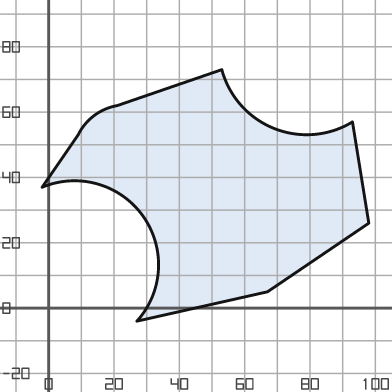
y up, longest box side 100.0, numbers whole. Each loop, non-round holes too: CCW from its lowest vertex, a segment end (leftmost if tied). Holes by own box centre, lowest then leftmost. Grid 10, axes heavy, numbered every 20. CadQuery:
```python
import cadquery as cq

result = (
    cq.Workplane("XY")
    .moveTo(27.0, -4.0)
    .lineTo(67.0, 5.0)
    .lineTo(98.0, 26.0)
    .lineTo(93.0, 57.0)
    .threePointArc((69.0, 55.0), (53.0, 73.0))
    .lineTo(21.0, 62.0)
    .threePointArc((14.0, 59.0), (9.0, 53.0))
    .lineTo(-2.0, 37.0)
    .threePointArc((29.0, 28.0), (27.0, -4.0))
    .close()
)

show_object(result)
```